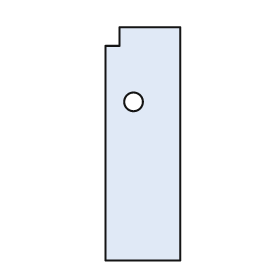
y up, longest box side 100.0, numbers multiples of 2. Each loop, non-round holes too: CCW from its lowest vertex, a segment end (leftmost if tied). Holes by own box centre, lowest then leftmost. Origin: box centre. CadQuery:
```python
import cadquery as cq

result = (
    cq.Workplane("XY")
    .moveTo(-16.0, -50.0)
    .lineTo(16.0, -50.0)
    .lineTo(16.0, 50.0)
    .lineTo(-10.0, 50.0)
    .lineTo(-10.0, 42.0)
    .lineTo(-16.0, 42.0)
    .close()
    .moveTo(-4.0, 18.0)
    .circle(4.0)
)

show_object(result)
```